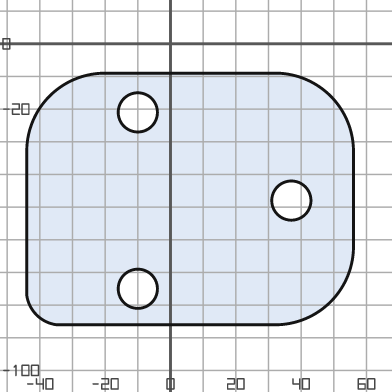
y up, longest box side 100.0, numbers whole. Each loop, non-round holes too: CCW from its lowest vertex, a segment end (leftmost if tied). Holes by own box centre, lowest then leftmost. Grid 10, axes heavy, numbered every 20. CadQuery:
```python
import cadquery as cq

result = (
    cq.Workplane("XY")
    .moveTo(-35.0, -86.0)
    .lineTo(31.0, -86.0)
    .threePointArc((49.0, -79.0), (56.0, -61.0))
    .lineTo(56.0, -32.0)
    .threePointArc((49.0, -16.0), (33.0, -9.0))
    .lineTo(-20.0, -9.0)
    .threePointArc((-37.0, -16.0), (-44.0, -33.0))
    .lineTo(-44.0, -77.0)
    .threePointArc((-41.0, -83.0), (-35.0, -86.0))
    .close()
    .moveTo(-10.0, -75.0)
    .circle(6.0)
    .moveTo(37.0, -48.0)
    .circle(6.0)
    .moveTo(-10.0, -21.0)
    .circle(6.0)
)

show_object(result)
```